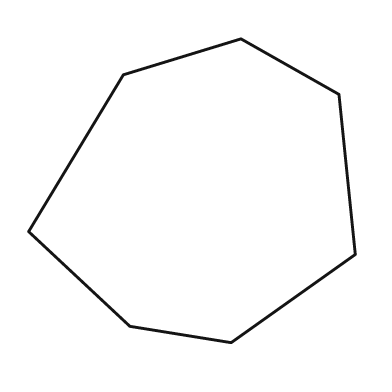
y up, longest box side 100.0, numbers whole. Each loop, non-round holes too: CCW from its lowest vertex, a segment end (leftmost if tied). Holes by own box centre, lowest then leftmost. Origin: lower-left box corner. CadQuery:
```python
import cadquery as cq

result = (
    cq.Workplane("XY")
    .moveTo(62.0, 0.0)
    .lineTo(100.0, 27.0)
    .lineTo(95.0, 76.0)
    .lineTo(65.0, 93.0)
    .lineTo(29.0, 82.0)
    .lineTo(0.0, 34.0)
    .lineTo(31.0, 5.0)
    .close()
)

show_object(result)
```